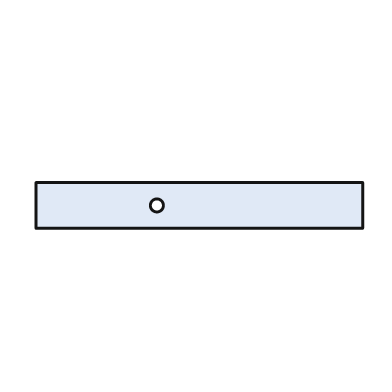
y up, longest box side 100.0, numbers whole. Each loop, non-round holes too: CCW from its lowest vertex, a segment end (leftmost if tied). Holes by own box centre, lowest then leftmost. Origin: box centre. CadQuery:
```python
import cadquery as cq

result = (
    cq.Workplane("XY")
    .moveTo(-50.0, -7.0)
    .lineTo(50.0, -7.0)
    .lineTo(50.0, 7.0)
    .lineTo(-50.0, 7.0)
    .close()
    .moveTo(-13.0, 0.0)
    .circle(2.0)
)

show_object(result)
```